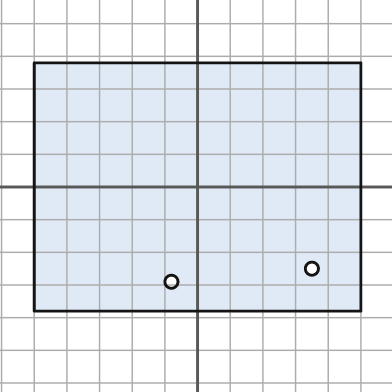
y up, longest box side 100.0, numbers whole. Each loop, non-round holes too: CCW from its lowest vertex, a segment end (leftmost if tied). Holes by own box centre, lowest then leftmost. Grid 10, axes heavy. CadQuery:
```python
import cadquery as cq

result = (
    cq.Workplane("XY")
    .moveTo(-50.0, -38.0)
    .lineTo(50.0, -38.0)
    .lineTo(50.0, 38.0)
    .lineTo(-50.0, 38.0)
    .close()
    .moveTo(-8.0, -29.0)
    .circle(2.0)
    .moveTo(35.0, -25.0)
    .circle(2.0)
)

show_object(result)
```